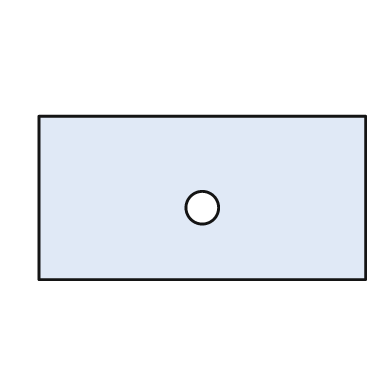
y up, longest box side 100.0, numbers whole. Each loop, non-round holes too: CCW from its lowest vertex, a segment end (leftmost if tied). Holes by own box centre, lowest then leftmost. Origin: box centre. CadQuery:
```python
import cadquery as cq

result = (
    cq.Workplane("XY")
    .moveTo(-50.0, -25.0)
    .lineTo(50.0, -25.0)
    .lineTo(50.0, 25.0)
    .lineTo(-50.0, 25.0)
    .close()
    .moveTo(0.0, -3.0)
    .circle(5.0)
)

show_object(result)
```